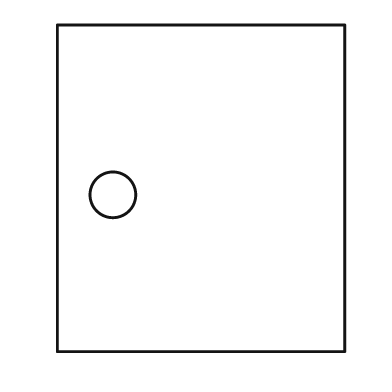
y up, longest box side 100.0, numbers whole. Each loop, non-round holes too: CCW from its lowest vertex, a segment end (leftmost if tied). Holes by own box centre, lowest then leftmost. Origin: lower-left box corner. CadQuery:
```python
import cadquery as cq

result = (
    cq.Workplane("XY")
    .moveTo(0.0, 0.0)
    .lineTo(88.0, 0.0)
    .lineTo(88.0, 100.0)
    .lineTo(0.0, 100.0)
    .close()
    .moveTo(17.0, 48.0)
    .circle(7.0)
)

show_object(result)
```